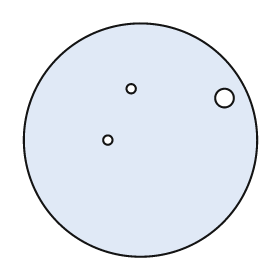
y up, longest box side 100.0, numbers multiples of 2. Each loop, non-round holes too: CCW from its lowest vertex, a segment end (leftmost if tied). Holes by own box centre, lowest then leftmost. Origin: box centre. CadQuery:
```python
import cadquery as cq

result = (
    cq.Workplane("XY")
    .moveTo(0.0, 0.0)
    .circle(50.0)
    .moveTo(-14.0, 0.0)
    .circle(2.0)
    .moveTo(36.0, 18.0)
    .circle(4.0)
    .moveTo(-4.0, 22.0)
    .circle(2.0)
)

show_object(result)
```